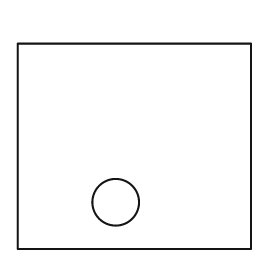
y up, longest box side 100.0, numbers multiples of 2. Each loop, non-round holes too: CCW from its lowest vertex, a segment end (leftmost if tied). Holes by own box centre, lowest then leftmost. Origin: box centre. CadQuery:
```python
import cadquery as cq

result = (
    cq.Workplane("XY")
    .moveTo(-50.0, -44.0)
    .lineTo(50.0, -44.0)
    .lineTo(50.0, 44.0)
    .lineTo(-50.0, 44.0)
    .close()
    .moveTo(-8.0, -24.0)
    .circle(10.0)
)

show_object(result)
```